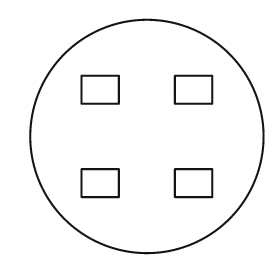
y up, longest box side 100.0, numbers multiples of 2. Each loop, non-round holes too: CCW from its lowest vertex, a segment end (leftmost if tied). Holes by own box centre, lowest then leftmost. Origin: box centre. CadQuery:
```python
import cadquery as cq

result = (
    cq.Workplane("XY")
    .moveTo(0.0, 0.0)
    .circle(50.0)
    .moveTo(-28.0, -26.0)
    .lineTo(-12.0, -26.0)
    .lineTo(-12.0, -14.0)
    .lineTo(-28.0, -14.0)
    .close()
    .moveTo(12.0, -26.0)
    .lineTo(28.0, -26.0)
    .lineTo(28.0, -14.0)
    .lineTo(12.0, -14.0)
    .close()
    .moveTo(-28.0, 14.0)
    .lineTo(-12.0, 14.0)
    .lineTo(-12.0, 26.0)
    .lineTo(-28.0, 26.0)
    .close()
    .moveTo(12.0, 14.0)
    .lineTo(28.0, 14.0)
    .lineTo(28.0, 26.0)
    .lineTo(12.0, 26.0)
    .close()
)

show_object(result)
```